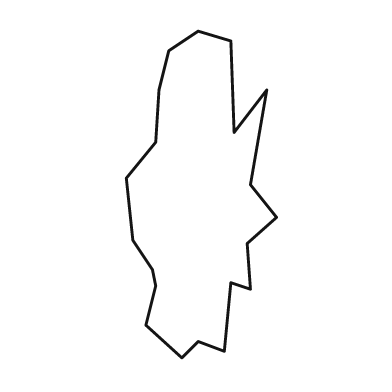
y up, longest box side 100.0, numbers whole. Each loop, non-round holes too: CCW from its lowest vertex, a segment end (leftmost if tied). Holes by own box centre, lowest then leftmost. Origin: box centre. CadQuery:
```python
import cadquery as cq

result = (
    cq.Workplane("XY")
    .moveTo(-6.0, -50.0)
    .lineTo(-1.0, -45.0)
    .lineTo(7.0, -48.0)
    .lineTo(9.0, -27.0)
    .lineTo(15.0, -29.0)
    .lineTo(14.0, -15.0)
    .lineTo(23.0, -7.0)
    .lineTo(15.0, 3.0)
    .lineTo(20.0, 32.0)
    .lineTo(10.0, 19.0)
    .lineTo(9.0, 47.0)
    .lineTo(-1.0, 50.0)
    .lineTo(-10.0, 44.0)
    .lineTo(-13.0, 32.0)
    .lineTo(-14.0, 16.0)
    .lineTo(-23.0, 5.0)
    .lineTo(-21.0, -14.0)
    .lineTo(-15.0, -23.0)
    .lineTo(-14.0, -28.0)
    .lineTo(-17.0, -40.0)
    .close()
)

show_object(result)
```